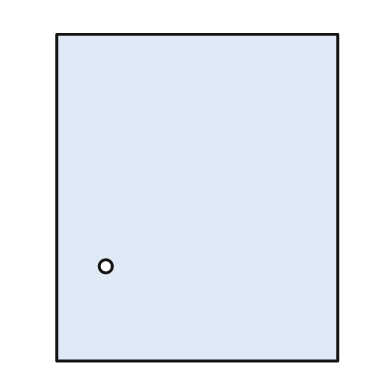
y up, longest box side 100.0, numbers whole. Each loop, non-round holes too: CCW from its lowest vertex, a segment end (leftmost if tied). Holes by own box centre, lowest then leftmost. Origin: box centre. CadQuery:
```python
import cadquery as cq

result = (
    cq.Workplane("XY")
    .moveTo(-43.0, -50.0)
    .lineTo(43.0, -50.0)
    .lineTo(43.0, 50.0)
    .lineTo(-43.0, 50.0)
    .close()
    .moveTo(-28.0, -21.0)
    .circle(2.0)
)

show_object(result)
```